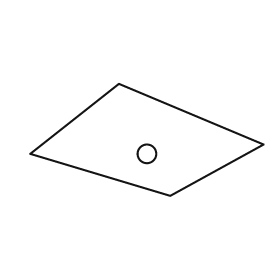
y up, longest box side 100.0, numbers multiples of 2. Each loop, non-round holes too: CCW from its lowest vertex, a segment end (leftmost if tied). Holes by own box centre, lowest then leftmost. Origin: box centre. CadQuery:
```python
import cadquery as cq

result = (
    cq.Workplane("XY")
    .moveTo(10.0, -24.0)
    .lineTo(50.0, -2.0)
    .lineTo(-12.0, 24.0)
    .lineTo(-50.0, -6.0)
    .close()
    .moveTo(0.0, -6.0)
    .circle(4.0)
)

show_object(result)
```